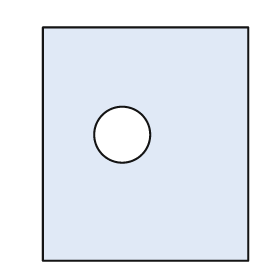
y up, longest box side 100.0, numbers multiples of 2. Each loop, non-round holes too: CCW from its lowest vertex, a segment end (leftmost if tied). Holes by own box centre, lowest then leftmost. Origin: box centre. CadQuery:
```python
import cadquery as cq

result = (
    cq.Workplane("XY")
    .moveTo(-44.0, -50.0)
    .lineTo(44.0, -50.0)
    .lineTo(44.0, 50.0)
    .lineTo(-44.0, 50.0)
    .close()
    .moveTo(-10.0, 4.0)
    .circle(12.0)
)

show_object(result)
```